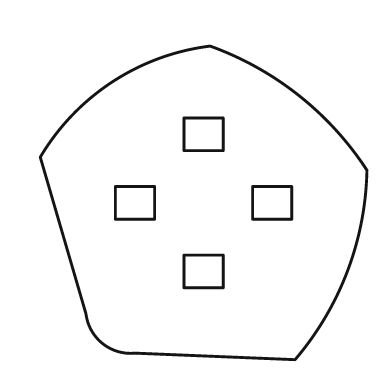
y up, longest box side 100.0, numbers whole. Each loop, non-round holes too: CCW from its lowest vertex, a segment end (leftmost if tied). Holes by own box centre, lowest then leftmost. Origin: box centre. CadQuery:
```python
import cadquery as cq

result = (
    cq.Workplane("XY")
    .moveTo(28.0, -48.0)
    .threePointArc((44.0, -21.0), (50.0, 10.0))
    .threePointArc((29.0, 33.0), (2.0, 48.0))
    .threePointArc((-28.0, 37.0), (-50.0, 14.0))
    .lineTo(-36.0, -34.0)
    .threePointArc((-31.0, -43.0), (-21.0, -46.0))
    .close()
    .moveTo(-6.0, -26.0)
    .lineTo(6.0, -26.0)
    .lineTo(6.0, -16.0)
    .lineTo(-6.0, -16.0)
    .close()
    .moveTo(-27.0, -5.0)
    .lineTo(-15.0, -5.0)
    .lineTo(-15.0, 5.0)
    .lineTo(-27.0, 5.0)
    .close()
    .moveTo(15.0, -5.0)
    .lineTo(27.0, -5.0)
    .lineTo(27.0, 5.0)
    .lineTo(15.0, 5.0)
    .close()
    .moveTo(-6.0, 16.0)
    .lineTo(6.0, 16.0)
    .lineTo(6.0, 26.0)
    .lineTo(-6.0, 26.0)
    .close()
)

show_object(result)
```